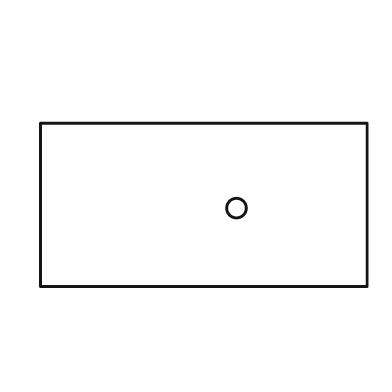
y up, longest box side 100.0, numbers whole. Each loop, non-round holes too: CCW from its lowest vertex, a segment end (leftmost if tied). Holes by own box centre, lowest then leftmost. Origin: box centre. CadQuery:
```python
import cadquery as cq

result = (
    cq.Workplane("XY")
    .moveTo(-50.0, -25.0)
    .lineTo(50.0, -25.0)
    .lineTo(50.0, 25.0)
    .lineTo(-50.0, 25.0)
    .close()
    .moveTo(10.0, -1.0)
    .circle(3.0)
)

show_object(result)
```